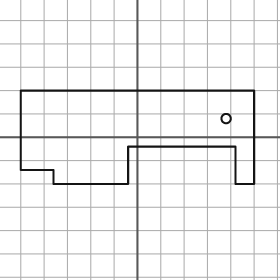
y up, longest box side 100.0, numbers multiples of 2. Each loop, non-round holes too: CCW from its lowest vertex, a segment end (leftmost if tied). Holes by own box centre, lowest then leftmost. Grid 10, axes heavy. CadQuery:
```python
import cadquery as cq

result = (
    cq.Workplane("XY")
    .moveTo(-36.0, -20.0)
    .lineTo(-4.0, -20.0)
    .lineTo(-4.0, -4.0)
    .lineTo(42.0, -4.0)
    .lineTo(42.0, -20.0)
    .lineTo(50.0, -20.0)
    .lineTo(50.0, 20.0)
    .lineTo(-50.0, 20.0)
    .lineTo(-50.0, -14.0)
    .lineTo(-36.0, -14.0)
    .close()
    .moveTo(38.0, 8.0)
    .circle(2.0)
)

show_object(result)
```